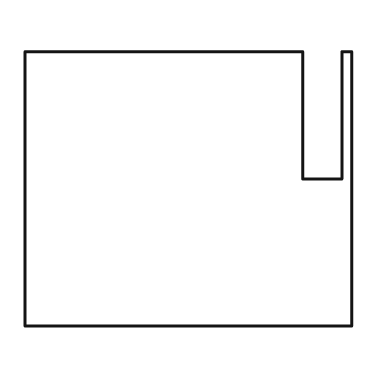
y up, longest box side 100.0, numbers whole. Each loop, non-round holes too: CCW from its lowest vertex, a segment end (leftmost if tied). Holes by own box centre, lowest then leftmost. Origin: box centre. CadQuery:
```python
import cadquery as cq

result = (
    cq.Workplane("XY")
    .moveTo(-50.0, -42.0)
    .lineTo(50.0, -42.0)
    .lineTo(50.0, 42.0)
    .lineTo(47.0, 42.0)
    .lineTo(47.0, 3.0)
    .lineTo(35.0, 3.0)
    .lineTo(35.0, 42.0)
    .lineTo(-50.0, 42.0)
    .close()
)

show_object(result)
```